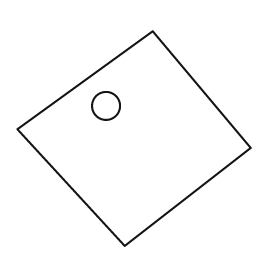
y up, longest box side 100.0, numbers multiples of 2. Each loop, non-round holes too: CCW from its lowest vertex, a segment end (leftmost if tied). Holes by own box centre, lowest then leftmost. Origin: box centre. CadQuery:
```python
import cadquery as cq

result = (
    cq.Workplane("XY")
    .moveTo(-4.0, -46.0)
    .lineTo(50.0, -4.0)
    .lineTo(8.0, 46.0)
    .lineTo(-50.0, 4.0)
    .close()
    .moveTo(-12.0, 14.0)
    .circle(6.0)
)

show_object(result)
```